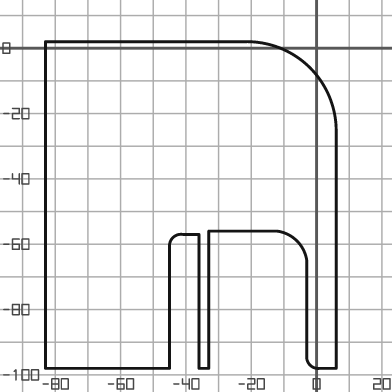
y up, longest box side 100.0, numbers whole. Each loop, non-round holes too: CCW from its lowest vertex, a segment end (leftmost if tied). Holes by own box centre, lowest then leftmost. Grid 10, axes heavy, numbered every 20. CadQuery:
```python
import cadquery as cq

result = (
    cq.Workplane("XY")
    .moveTo(-83.0, -98.0)
    .lineTo(-45.0, -98.0)
    .lineTo(-45.0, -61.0)
    .threePointArc((-44.0, -58.0), (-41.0, -57.0))
    .lineTo(-36.0, -57.0)
    .lineTo(-36.0, -98.0)
    .lineTo(-33.0, -98.0)
    .lineTo(-33.0, -56.0)
    .lineTo(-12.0, -56.0)
    .threePointArc((-6.0, -59.0), (-3.0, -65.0))
    .lineTo(-3.0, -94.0)
    .threePointArc((-2.0, -97.0), (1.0, -98.0))
    .lineTo(6.0, -98.0)
    .lineTo(6.0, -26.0)
    .threePointArc((-2.0, -6.0), (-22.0, 2.0))
    .lineTo(-83.0, 2.0)
    .close()
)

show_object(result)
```